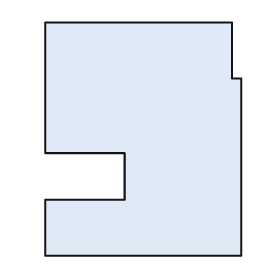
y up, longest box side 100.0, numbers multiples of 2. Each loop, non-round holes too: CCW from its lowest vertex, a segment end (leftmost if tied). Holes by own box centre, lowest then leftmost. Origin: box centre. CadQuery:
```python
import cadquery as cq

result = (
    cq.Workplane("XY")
    .moveTo(-42.0, -50.0)
    .lineTo(42.0, -50.0)
    .lineTo(42.0, 26.0)
    .lineTo(38.0, 26.0)
    .lineTo(38.0, 50.0)
    .lineTo(-42.0, 50.0)
    .lineTo(-42.0, -6.0)
    .lineTo(-8.0, -6.0)
    .lineTo(-8.0, -26.0)
    .lineTo(-42.0, -26.0)
    .close()
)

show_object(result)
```